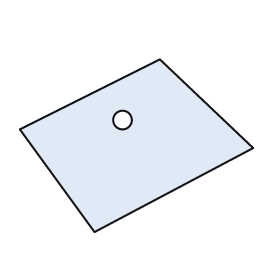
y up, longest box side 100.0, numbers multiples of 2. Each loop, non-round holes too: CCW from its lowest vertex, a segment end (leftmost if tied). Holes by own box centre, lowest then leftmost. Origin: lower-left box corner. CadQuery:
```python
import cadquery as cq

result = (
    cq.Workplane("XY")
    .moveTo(32.0, 0.0)
    .lineTo(100.0, 36.0)
    .lineTo(60.0, 74.0)
    .lineTo(0.0, 44.0)
    .close()
    .moveTo(44.0, 48.0)
    .circle(4.0)
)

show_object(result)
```